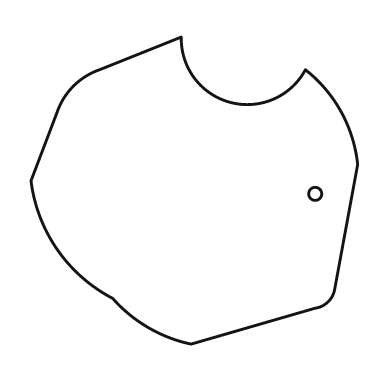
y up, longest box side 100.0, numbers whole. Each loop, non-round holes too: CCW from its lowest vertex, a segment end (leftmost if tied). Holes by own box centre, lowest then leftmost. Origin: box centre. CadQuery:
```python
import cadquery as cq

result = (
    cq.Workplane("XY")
    .moveTo(-1.0, -47.0)
    .lineTo(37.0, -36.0)
    .threePointArc((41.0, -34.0), (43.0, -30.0))
    .lineTo(50.0, 8.0)
    .threePointArc((45.0, 24.0), (34.0, 37.0))
    .threePointArc((11.0, 27.0), (-4.0, 47.0))
    .lineTo(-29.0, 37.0)
    .threePointArc((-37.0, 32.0), (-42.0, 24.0))
    .lineTo(-50.0, 3.0)
    .threePointArc((-42.0, -18.0), (-25.0, -33.0))
    .threePointArc((-14.0, -42.0), (-1.0, -47.0))
    .close()
    .moveTo(37.0, -1.0)
    .circle(2.0)
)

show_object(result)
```